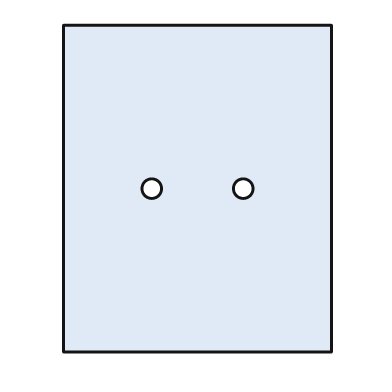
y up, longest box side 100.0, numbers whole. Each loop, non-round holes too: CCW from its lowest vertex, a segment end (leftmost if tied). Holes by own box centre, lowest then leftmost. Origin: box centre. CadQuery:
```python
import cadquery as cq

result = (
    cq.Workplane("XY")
    .moveTo(-41.0, -50.0)
    .lineTo(41.0, -50.0)
    .lineTo(41.0, 50.0)
    .lineTo(-41.0, 50.0)
    .close()
    .moveTo(-14.0, 0.0)
    .circle(3.0)
    .moveTo(14.0, 0.0)
    .circle(3.0)
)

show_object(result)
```